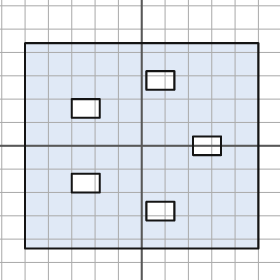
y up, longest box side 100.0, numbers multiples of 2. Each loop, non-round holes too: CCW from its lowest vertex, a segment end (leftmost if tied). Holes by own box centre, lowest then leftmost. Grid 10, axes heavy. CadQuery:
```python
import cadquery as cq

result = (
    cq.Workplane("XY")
    .moveTo(-50.0, -44.0)
    .lineTo(50.0, -44.0)
    .lineTo(50.0, 44.0)
    .lineTo(-50.0, 44.0)
    .close()
    .moveTo(2.0, -32.0)
    .lineTo(14.0, -32.0)
    .lineTo(14.0, -24.0)
    .lineTo(2.0, -24.0)
    .close()
    .moveTo(-30.0, -20.0)
    .lineTo(-18.0, -20.0)
    .lineTo(-18.0, -12.0)
    .lineTo(-30.0, -12.0)
    .close()
    .moveTo(22.0, -4.0)
    .lineTo(34.0, -4.0)
    .lineTo(34.0, 4.0)
    .lineTo(22.0, 4.0)
    .close()
    .moveTo(-30.0, 12.0)
    .lineTo(-18.0, 12.0)
    .lineTo(-18.0, 20.0)
    .lineTo(-30.0, 20.0)
    .close()
    .moveTo(2.0, 24.0)
    .lineTo(14.0, 24.0)
    .lineTo(14.0, 32.0)
    .lineTo(2.0, 32.0)
    .close()
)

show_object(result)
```